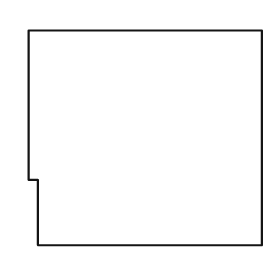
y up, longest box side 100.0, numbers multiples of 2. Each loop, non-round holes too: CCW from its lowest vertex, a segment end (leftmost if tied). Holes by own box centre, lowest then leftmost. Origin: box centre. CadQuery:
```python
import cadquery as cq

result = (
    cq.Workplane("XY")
    .moveTo(-46.0, -46.0)
    .lineTo(50.0, -46.0)
    .lineTo(50.0, 46.0)
    .lineTo(-50.0, 46.0)
    .lineTo(-50.0, -18.0)
    .lineTo(-46.0, -18.0)
    .close()
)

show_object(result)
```